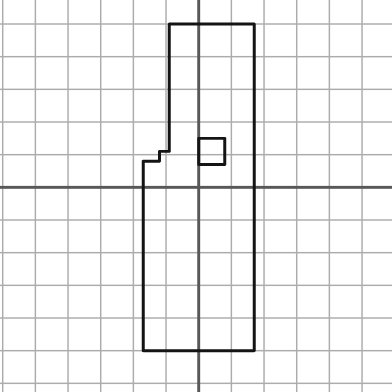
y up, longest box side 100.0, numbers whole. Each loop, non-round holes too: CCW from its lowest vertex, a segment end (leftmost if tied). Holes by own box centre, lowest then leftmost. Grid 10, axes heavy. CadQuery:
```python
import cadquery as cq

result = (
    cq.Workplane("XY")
    .moveTo(-17.0, -50.0)
    .lineTo(17.0, -50.0)
    .lineTo(17.0, 50.0)
    .lineTo(-9.0, 50.0)
    .lineTo(-9.0, 11.0)
    .lineTo(-12.0, 11.0)
    .lineTo(-12.0, 8.0)
    .lineTo(-17.0, 8.0)
    .close()
    .moveTo(0.0, 7.0)
    .lineTo(8.0, 7.0)
    .lineTo(8.0, 15.0)
    .lineTo(0.0, 15.0)
    .close()
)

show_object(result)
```